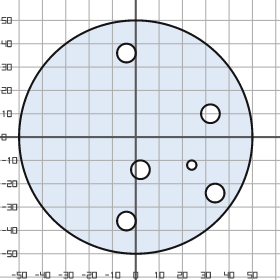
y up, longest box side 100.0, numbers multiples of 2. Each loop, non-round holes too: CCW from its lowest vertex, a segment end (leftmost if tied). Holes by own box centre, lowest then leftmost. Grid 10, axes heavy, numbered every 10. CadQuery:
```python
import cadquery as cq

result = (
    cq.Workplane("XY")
    .moveTo(0.0, 0.0)
    .circle(50.0)
    .moveTo(-4.0, -36.0)
    .circle(4.0)
    .moveTo(34.0, -24.0)
    .circle(4.0)
    .moveTo(2.0, -14.0)
    .circle(4.0)
    .moveTo(24.0, -12.0)
    .circle(2.0)
    .moveTo(32.0, 10.0)
    .circle(4.0)
    .moveTo(-4.0, 36.0)
    .circle(4.0)
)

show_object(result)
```